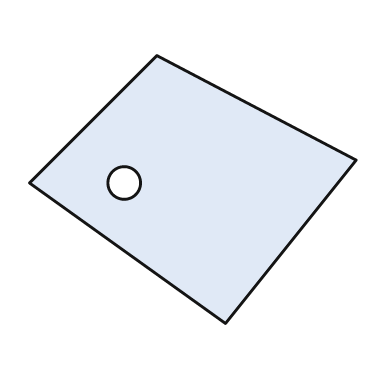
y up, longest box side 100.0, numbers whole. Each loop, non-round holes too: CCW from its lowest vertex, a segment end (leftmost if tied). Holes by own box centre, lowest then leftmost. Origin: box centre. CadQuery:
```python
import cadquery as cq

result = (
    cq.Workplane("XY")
    .moveTo(10.0, -41.0)
    .lineTo(50.0, 9.0)
    .lineTo(-11.0, 41.0)
    .lineTo(-50.0, 2.0)
    .close()
    .moveTo(-21.0, 2.0)
    .circle(5.0)
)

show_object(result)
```